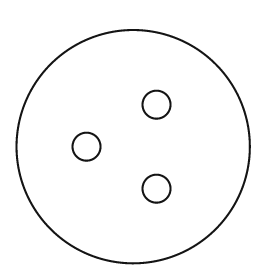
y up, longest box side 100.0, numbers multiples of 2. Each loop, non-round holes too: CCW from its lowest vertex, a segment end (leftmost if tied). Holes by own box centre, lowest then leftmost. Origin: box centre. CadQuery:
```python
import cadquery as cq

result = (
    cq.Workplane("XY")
    .moveTo(0.0, 0.0)
    .circle(50.0)
    .moveTo(10.0, -18.0)
    .circle(6.0)
    .moveTo(-20.0, 0.0)
    .circle(6.0)
    .moveTo(10.0, 18.0)
    .circle(6.0)
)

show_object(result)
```